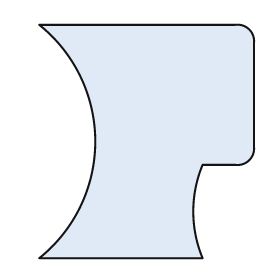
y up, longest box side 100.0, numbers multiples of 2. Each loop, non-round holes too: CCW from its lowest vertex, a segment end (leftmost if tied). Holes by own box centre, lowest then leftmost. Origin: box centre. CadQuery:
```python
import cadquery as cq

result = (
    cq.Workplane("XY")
    .moveTo(-46.0, -50.0)
    .lineTo(24.0, -50.0)
    .threePointArc((20.0, -30.0), (24.0, -10.0))
    .lineTo(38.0, -10.0)
    .threePointArc((44.0, -8.0), (46.0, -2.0))
    .lineTo(46.0, 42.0)
    .threePointArc((44.0, 48.0), (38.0, 50.0))
    .lineTo(-46.0, 50.0)
    .threePointArc((-22.0, 0.0), (-46.0, -50.0))
    .close()
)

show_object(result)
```